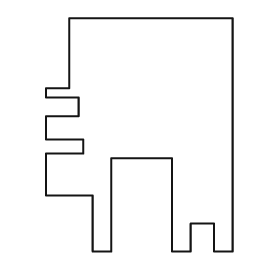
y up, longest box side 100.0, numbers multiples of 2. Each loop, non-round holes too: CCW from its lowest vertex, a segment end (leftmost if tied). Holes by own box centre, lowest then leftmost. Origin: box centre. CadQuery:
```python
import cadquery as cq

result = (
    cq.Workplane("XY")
    .moveTo(-20.0, -50.0)
    .lineTo(-12.0, -50.0)
    .lineTo(-12.0, -10.0)
    .lineTo(14.0, -10.0)
    .lineTo(14.0, -50.0)
    .lineTo(22.0, -50.0)
    .lineTo(22.0, -38.0)
    .lineTo(32.0, -38.0)
    .lineTo(32.0, -50.0)
    .lineTo(40.0, -50.0)
    .lineTo(40.0, 50.0)
    .lineTo(-30.0, 50.0)
    .lineTo(-30.0, 20.0)
    .lineTo(-40.0, 20.0)
    .lineTo(-40.0, 16.0)
    .lineTo(-26.0, 16.0)
    .lineTo(-26.0, 8.0)
    .lineTo(-40.0, 8.0)
    .lineTo(-40.0, -2.0)
    .lineTo(-24.0, -2.0)
    .lineTo(-24.0, -8.0)
    .lineTo(-40.0, -8.0)
    .lineTo(-40.0, -26.0)
    .lineTo(-20.0, -26.0)
    .close()
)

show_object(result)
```